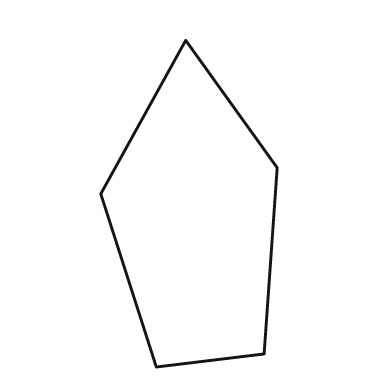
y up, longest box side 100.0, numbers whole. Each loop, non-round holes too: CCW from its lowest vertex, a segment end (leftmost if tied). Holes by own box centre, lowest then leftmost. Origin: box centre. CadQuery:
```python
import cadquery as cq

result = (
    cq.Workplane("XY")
    .moveTo(-10.0, -50.0)
    .lineTo(23.0, -46.0)
    .lineTo(27.0, 11.0)
    .lineTo(-1.0, 50.0)
    .lineTo(-27.0, 3.0)
    .close()
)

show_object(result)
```